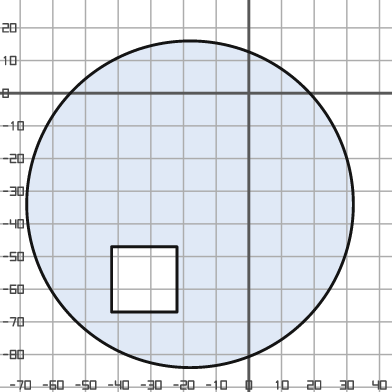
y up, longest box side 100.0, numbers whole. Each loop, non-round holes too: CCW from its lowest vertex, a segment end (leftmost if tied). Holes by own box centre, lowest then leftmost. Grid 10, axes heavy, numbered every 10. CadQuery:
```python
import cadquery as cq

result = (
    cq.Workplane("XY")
    .moveTo(-18.0, -34.0)
    .circle(50.0)
    .moveTo(-42.0, -67.0)
    .lineTo(-22.0, -67.0)
    .lineTo(-22.0, -47.0)
    .lineTo(-42.0, -47.0)
    .close()
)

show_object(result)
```